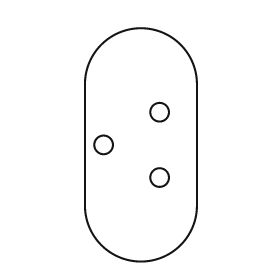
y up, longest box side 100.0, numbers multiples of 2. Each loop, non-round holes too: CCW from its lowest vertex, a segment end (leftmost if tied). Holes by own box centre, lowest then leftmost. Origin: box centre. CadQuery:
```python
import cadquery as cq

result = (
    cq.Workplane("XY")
    .moveTo(-24.0, -26.0)
    .threePointArc((0.0, -50.0), (24.0, -26.0))
    .lineTo(24.0, 26.0)
    .threePointArc((0.0, 50.0), (-24.0, 26.0))
    .close()
    .moveTo(8.0, -14.0)
    .circle(4.0)
    .moveTo(-16.0, 0.0)
    .circle(4.0)
    .moveTo(8.0, 14.0)
    .circle(4.0)
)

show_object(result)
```